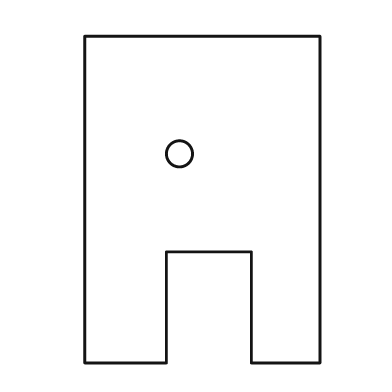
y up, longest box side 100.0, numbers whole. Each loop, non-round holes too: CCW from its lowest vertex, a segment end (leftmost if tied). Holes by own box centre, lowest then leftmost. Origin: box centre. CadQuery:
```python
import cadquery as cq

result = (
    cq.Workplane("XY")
    .moveTo(-36.0, -50.0)
    .lineTo(-11.0, -50.0)
    .lineTo(-11.0, -16.0)
    .lineTo(15.0, -16.0)
    .lineTo(15.0, -50.0)
    .lineTo(36.0, -50.0)
    .lineTo(36.0, 50.0)
    .lineTo(-36.0, 50.0)
    .close()
    .moveTo(-7.0, 14.0)
    .circle(4.0)
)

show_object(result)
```